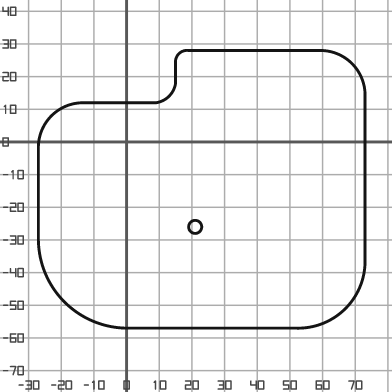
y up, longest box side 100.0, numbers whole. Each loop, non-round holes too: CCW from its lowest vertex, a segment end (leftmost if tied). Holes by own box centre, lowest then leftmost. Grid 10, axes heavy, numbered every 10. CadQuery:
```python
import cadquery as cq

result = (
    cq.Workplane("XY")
    .moveTo(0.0, -57.0)
    .lineTo(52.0, -57.0)
    .threePointArc((67.0, -51.0), (73.0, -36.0))
    .lineTo(73.0, 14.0)
    .threePointArc((69.0, 24.0), (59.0, 28.0))
    .lineTo(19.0, 28.0)
    .threePointArc((16.0, 27.0), (15.0, 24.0))
    .lineTo(15.0, 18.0)
    .threePointArc((13.0, 14.0), (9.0, 12.0))
    .lineTo(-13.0, 12.0)
    .threePointArc((-23.0, 8.0), (-27.0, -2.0))
    .lineTo(-27.0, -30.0)
    .threePointArc((-19.0, -49.0), (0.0, -57.0))
    .close()
    .moveTo(21.0, -26.0)
    .circle(2.0)
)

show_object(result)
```